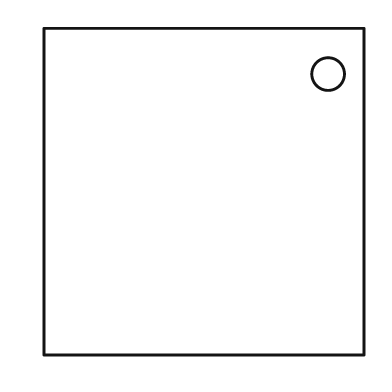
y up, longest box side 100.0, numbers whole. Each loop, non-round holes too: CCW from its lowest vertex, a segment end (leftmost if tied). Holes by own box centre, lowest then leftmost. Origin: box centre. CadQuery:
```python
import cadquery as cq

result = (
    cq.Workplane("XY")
    .moveTo(-49.0, -50.0)
    .lineTo(49.0, -50.0)
    .lineTo(49.0, 50.0)
    .lineTo(-49.0, 50.0)
    .close()
    .moveTo(38.0, 36.0)
    .circle(5.0)
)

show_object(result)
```